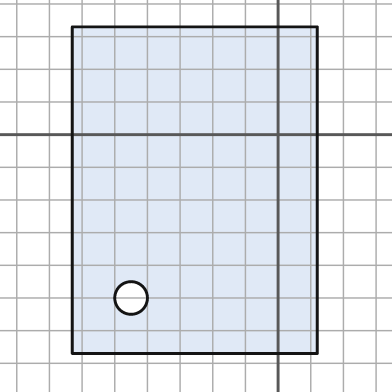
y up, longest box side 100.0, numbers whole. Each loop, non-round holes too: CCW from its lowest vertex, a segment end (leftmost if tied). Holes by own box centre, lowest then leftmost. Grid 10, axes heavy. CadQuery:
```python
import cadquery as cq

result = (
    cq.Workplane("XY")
    .moveTo(-63.0, -67.0)
    .lineTo(12.0, -67.0)
    .lineTo(12.0, 33.0)
    .lineTo(-63.0, 33.0)
    .close()
    .moveTo(-45.0, -50.0)
    .circle(5.0)
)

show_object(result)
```